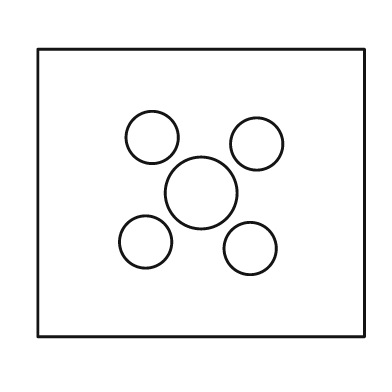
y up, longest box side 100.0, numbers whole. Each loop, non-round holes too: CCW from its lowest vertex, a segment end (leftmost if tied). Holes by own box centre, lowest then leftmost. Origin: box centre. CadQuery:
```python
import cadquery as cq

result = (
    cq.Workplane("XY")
    .moveTo(-50.0, -44.0)
    .lineTo(50.0, -44.0)
    .lineTo(50.0, 44.0)
    .lineTo(-50.0, 44.0)
    .close()
    .moveTo(15.0, -17.0)
    .circle(8.0)
    .moveTo(-17.0, -15.0)
    .circle(8.0)
    .moveTo(0.0, 0.0)
    .circle(11.0)
    .moveTo(17.0, 15.0)
    .circle(8.0)
    .moveTo(-15.0, 17.0)
    .circle(8.0)
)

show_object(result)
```